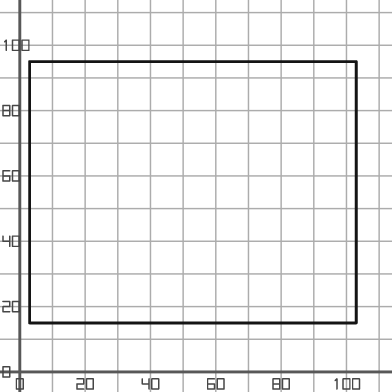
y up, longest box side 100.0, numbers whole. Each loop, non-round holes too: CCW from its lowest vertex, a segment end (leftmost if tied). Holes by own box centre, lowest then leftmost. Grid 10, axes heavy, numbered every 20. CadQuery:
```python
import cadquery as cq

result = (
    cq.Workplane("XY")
    .moveTo(3.0, 15.0)
    .lineTo(103.0, 15.0)
    .lineTo(103.0, 95.0)
    .lineTo(3.0, 95.0)
    .close()
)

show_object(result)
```